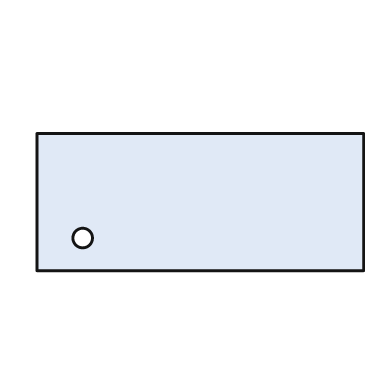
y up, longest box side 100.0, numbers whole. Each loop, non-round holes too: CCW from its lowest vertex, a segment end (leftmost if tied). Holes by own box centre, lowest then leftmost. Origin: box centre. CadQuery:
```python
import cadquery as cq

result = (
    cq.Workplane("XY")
    .moveTo(-50.0, -21.0)
    .lineTo(50.0, -21.0)
    .lineTo(50.0, 21.0)
    .lineTo(-50.0, 21.0)
    .close()
    .moveTo(-36.0, -11.0)
    .circle(3.0)
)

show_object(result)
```